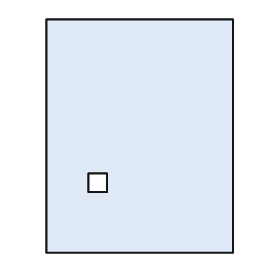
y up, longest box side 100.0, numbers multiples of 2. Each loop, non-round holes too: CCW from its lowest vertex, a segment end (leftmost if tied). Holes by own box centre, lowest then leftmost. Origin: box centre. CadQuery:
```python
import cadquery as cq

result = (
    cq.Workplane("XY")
    .moveTo(-40.0, -50.0)
    .lineTo(40.0, -50.0)
    .lineTo(40.0, 50.0)
    .lineTo(-40.0, 50.0)
    .close()
    .moveTo(-22.0, -24.0)
    .lineTo(-14.0, -24.0)
    .lineTo(-14.0, -16.0)
    .lineTo(-22.0, -16.0)
    .close()
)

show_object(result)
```